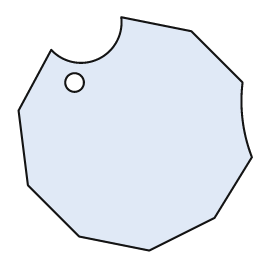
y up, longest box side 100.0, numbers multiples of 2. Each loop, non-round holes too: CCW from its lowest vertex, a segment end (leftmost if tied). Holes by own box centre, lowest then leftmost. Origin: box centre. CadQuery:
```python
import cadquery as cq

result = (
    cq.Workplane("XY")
    .moveTo(6.0, -50.0)
    .lineTo(34.0, -36.0)
    .lineTo(50.0, -10.0)
    .threePointArc((46.0, 6.0), (46.0, 22.0))
    .lineTo(24.0, 44.0)
    .lineTo(-6.0, 50.0)
    .threePointArc((-16.0, 32.0), (-36.0, 36.0))
    .lineTo(-50.0, 10.0)
    .lineTo(-46.0, -22.0)
    .lineTo(-24.0, -44.0)
    .close()
    .moveTo(-26.0, 22.0)
    .circle(4.0)
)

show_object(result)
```